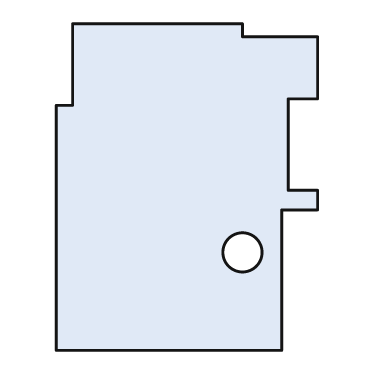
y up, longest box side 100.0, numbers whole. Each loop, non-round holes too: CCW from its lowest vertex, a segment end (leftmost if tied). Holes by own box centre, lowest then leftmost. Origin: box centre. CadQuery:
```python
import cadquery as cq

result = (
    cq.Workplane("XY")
    .moveTo(-40.0, -50.0)
    .lineTo(29.0, -50.0)
    .lineTo(29.0, -7.0)
    .lineTo(40.0, -7.0)
    .lineTo(40.0, -1.0)
    .lineTo(31.0, -1.0)
    .lineTo(31.0, 27.0)
    .lineTo(40.0, 27.0)
    .lineTo(40.0, 46.0)
    .lineTo(17.0, 46.0)
    .lineTo(17.0, 50.0)
    .lineTo(-35.0, 50.0)
    .lineTo(-35.0, 25.0)
    .lineTo(-40.0, 25.0)
    .close()
    .moveTo(17.0, -20.0)
    .circle(6.0)
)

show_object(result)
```